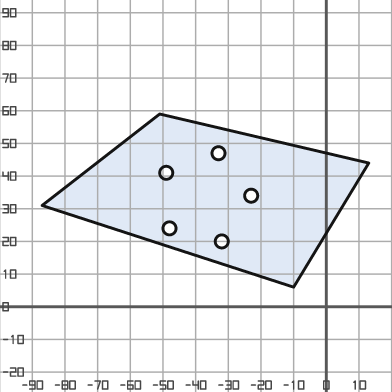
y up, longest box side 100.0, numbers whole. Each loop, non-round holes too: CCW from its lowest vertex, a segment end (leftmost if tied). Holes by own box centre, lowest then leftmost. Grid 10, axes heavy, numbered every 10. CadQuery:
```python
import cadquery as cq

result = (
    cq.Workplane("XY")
    .moveTo(-10.0, 6.0)
    .lineTo(13.0, 44.0)
    .lineTo(-51.0, 59.0)
    .lineTo(-87.0, 31.0)
    .close()
    .moveTo(-32.0, 20.0)
    .circle(2.0)
    .moveTo(-48.0, 24.0)
    .circle(2.0)
    .moveTo(-23.0, 34.0)
    .circle(2.0)
    .moveTo(-49.0, 41.0)
    .circle(2.0)
    .moveTo(-33.0, 47.0)
    .circle(2.0)
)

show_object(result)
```